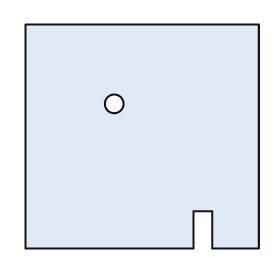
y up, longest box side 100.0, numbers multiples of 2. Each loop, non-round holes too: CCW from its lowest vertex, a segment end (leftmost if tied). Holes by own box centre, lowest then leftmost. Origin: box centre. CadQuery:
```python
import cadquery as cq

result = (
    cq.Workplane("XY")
    .moveTo(-50.0, -48.0)
    .lineTo(22.0, -48.0)
    .lineTo(22.0, -32.0)
    .lineTo(30.0, -32.0)
    .lineTo(30.0, -48.0)
    .lineTo(50.0, -48.0)
    .lineTo(50.0, 48.0)
    .lineTo(-50.0, 48.0)
    .close()
    .moveTo(-12.0, 14.0)
    .circle(4.0)
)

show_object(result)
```